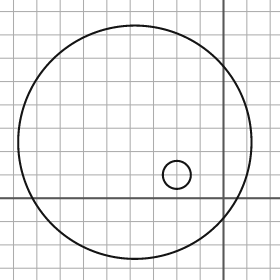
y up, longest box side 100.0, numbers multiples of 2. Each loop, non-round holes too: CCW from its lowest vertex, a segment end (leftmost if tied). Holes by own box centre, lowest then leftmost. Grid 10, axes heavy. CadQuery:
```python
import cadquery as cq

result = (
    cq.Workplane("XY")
    .moveTo(-38.0, 24.0)
    .circle(50.0)
    .moveTo(-20.0, 10.0)
    .circle(6.0)
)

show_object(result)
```